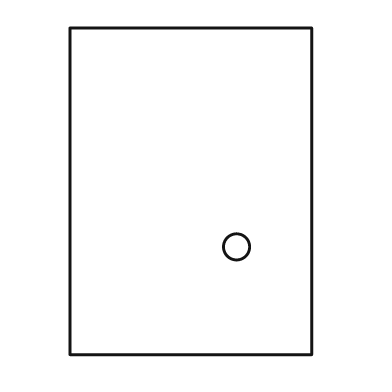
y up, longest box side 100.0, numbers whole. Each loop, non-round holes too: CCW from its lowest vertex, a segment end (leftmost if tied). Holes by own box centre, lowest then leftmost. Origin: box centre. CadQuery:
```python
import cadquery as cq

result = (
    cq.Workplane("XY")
    .moveTo(-37.0, -50.0)
    .lineTo(37.0, -50.0)
    .lineTo(37.0, 50.0)
    .lineTo(-37.0, 50.0)
    .close()
    .moveTo(14.0, -17.0)
    .circle(4.0)
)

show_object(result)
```